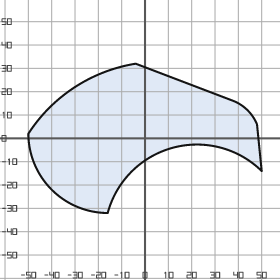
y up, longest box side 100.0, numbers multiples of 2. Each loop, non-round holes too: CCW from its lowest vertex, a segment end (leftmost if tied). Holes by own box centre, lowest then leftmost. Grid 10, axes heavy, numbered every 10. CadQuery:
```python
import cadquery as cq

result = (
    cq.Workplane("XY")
    .moveTo(-16.0, -32.0)
    .threePointArc((12.0, -4.0), (50.0, -14.0))
    .lineTo(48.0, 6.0)
    .threePointArc((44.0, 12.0), (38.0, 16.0))
    .lineTo(-4.0, 32.0)
    .threePointArc((-30.0, 22.0), (-50.0, 2.0))
    .threePointArc((-40.0, -22.0), (-16.0, -32.0))
    .close()
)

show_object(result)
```